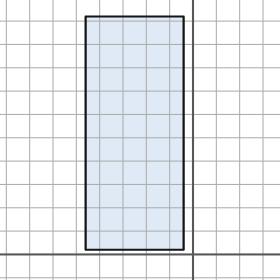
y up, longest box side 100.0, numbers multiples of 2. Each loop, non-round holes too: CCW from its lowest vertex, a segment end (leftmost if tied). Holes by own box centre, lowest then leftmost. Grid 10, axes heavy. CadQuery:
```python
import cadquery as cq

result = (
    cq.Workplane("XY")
    .moveTo(-46.0, 2.0)
    .lineTo(-4.0, 2.0)
    .lineTo(-4.0, 102.0)
    .lineTo(-46.0, 102.0)
    .close()
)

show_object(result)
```